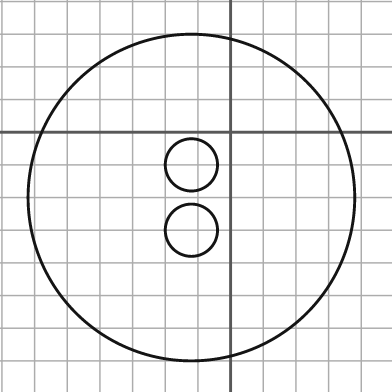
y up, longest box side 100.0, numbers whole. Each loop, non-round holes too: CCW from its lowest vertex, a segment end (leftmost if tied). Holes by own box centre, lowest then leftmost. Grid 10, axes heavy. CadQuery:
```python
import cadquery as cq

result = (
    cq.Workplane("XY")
    .moveTo(-12.0, -20.0)
    .circle(50.0)
    .moveTo(-12.0, -30.0)
    .circle(8.0)
    .moveTo(-12.0, -10.0)
    .circle(8.0)
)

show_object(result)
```